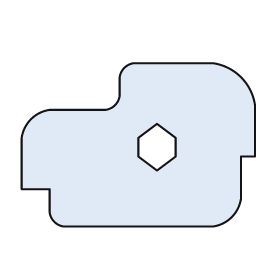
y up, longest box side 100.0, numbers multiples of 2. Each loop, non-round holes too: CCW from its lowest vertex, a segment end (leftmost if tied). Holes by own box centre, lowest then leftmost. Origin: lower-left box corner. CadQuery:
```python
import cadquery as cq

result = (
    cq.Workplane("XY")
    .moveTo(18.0, 0.0)
    .lineTo(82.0, 0.0)
    .threePointArc((90.0, 4.0), (94.0, 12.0))
    .lineTo(94.0, 30.0)
    .lineTo(100.0, 30.0)
    .lineTo(100.0, 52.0)
    .threePointArc((94.0, 64.0), (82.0, 70.0))
    .lineTo(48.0, 70.0)
    .threePointArc((44.0, 68.0), (42.0, 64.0))
    .lineTo(42.0, 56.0)
    .threePointArc((40.0, 52.0), (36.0, 50.0))
    .lineTo(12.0, 50.0)
    .threePointArc((4.0, 46.0), (0.0, 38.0))
    .lineTo(0.0, 16.0)
    .lineTo(12.0, 16.0)
    .lineTo(12.0, 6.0)
    .threePointArc((14.0, 2.0), (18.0, 0.0))
    .close()
    .moveTo(58.0, 24.0)
    .lineTo(66.0, 30.0)
    .lineTo(66.0, 38.0)
    .lineTo(58.0, 44.0)
    .lineTo(50.0, 38.0)
    .lineTo(50.0, 30.0)
    .close()
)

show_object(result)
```